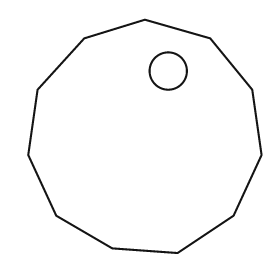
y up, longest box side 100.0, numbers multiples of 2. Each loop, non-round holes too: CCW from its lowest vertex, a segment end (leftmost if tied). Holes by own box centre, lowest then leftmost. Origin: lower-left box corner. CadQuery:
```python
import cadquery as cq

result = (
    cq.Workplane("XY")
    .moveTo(64.0, 0.0)
    .lineTo(88.0, 16.0)
    .lineTo(100.0, 42.0)
    .lineTo(96.0, 70.0)
    .lineTo(78.0, 92.0)
    .lineTo(50.0, 100.0)
    .lineTo(24.0, 92.0)
    .lineTo(4.0, 70.0)
    .lineTo(0.0, 42.0)
    .lineTo(12.0, 16.0)
    .lineTo(36.0, 2.0)
    .close()
    .moveTo(60.0, 78.0)
    .circle(8.0)
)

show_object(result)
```